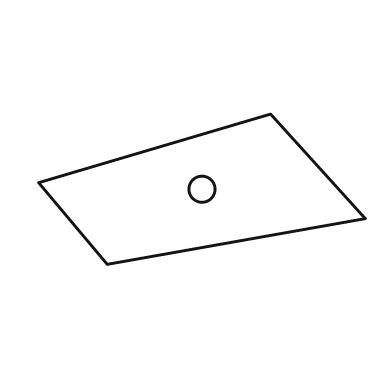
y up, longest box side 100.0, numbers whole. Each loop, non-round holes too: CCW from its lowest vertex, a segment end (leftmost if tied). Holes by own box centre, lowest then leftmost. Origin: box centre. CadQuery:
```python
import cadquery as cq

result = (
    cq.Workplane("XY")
    .moveTo(-29.0, -23.0)
    .lineTo(50.0, -9.0)
    .lineTo(21.0, 23.0)
    .lineTo(-50.0, 2.0)
    .close()
    .moveTo(0.0, 0.0)
    .circle(4.0)
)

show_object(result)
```